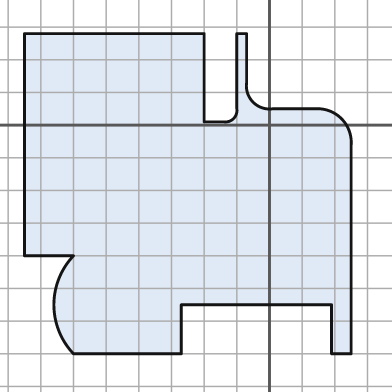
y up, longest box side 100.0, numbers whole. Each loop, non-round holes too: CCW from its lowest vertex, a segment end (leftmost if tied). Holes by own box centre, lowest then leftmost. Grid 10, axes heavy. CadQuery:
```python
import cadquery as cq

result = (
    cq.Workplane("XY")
    .moveTo(-60.0, -70.0)
    .lineTo(-27.0, -70.0)
    .lineTo(-27.0, -55.0)
    .lineTo(19.0, -55.0)
    .lineTo(19.0, -70.0)
    .lineTo(25.0, -70.0)
    .lineTo(25.0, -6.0)
    .threePointArc((22.0, 2.0), (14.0, 5.0))
    .lineTo(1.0, 5.0)
    .threePointArc((-5.0, 7.0), (-7.0, 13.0))
    .lineTo(-7.0, 28.0)
    .lineTo(-10.0, 28.0)
    .lineTo(-10.0, 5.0)
    .threePointArc((-11.0, 2.0), (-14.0, 1.0))
    .lineTo(-20.0, 1.0)
    .lineTo(-20.0, 28.0)
    .lineTo(-75.0, 28.0)
    .lineTo(-75.0, -40.0)
    .lineTo(-60.0, -40.0)
    .threePointArc((-66.0, -55.0), (-60.0, -70.0))
    .close()
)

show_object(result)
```